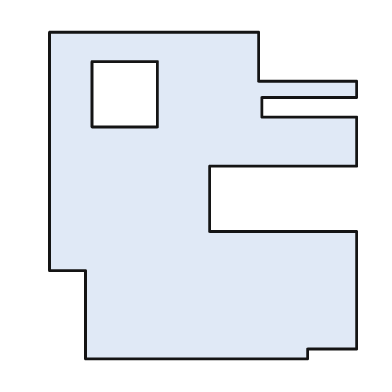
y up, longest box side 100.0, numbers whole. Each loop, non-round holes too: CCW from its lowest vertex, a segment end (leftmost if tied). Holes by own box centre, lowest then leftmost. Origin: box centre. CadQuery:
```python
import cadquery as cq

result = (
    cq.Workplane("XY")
    .moveTo(-36.0, -50.0)
    .lineTo(32.0, -50.0)
    .lineTo(32.0, -47.0)
    .lineTo(47.0, -47.0)
    .lineTo(47.0, -11.0)
    .lineTo(2.0, -11.0)
    .lineTo(2.0, 9.0)
    .lineTo(47.0, 9.0)
    .lineTo(47.0, 24.0)
    .lineTo(18.0, 24.0)
    .lineTo(18.0, 30.0)
    .lineTo(47.0, 30.0)
    .lineTo(47.0, 35.0)
    .lineTo(17.0, 35.0)
    .lineTo(17.0, 50.0)
    .lineTo(-47.0, 50.0)
    .lineTo(-47.0, -23.0)
    .lineTo(-36.0, -23.0)
    .close()
    .moveTo(-34.0, 21.0)
    .lineTo(-14.0, 21.0)
    .lineTo(-14.0, 41.0)
    .lineTo(-34.0, 41.0)
    .close()
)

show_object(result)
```